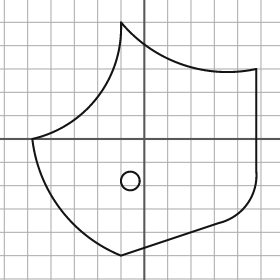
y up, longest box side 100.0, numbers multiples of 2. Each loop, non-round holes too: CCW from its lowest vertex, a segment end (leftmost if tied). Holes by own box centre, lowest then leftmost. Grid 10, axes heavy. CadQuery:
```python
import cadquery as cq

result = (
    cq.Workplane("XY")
    .moveTo(-10.0, -50.0)
    .lineTo(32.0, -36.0)
    .threePointArc((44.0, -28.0), (48.0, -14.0))
    .lineTo(48.0, 30.0)
    .threePointArc((16.0, 32.0), (-10.0, 50.0))
    .threePointArc((-20.0, 18.0), (-48.0, 0.0))
    .threePointArc((-36.0, -30.0), (-10.0, -50.0))
    .close()
    .moveTo(-6.0, -18.0)
    .circle(4.0)
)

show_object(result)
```